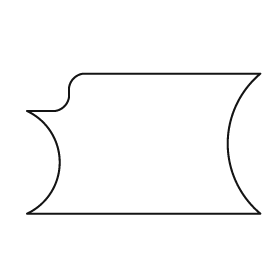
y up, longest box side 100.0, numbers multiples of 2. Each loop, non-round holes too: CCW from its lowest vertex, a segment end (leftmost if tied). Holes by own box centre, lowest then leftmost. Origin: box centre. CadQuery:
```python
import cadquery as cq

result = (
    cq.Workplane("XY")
    .moveTo(-50.0, -30.0)
    .lineTo(50.0, -30.0)
    .threePointArc((36.0, 0.0), (50.0, 30.0))
    .lineTo(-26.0, 30.0)
    .threePointArc((-30.0, 28.0), (-32.0, 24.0))
    .lineTo(-32.0, 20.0)
    .threePointArc((-34.0, 16.0), (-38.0, 14.0))
    .lineTo(-50.0, 14.0)
    .threePointArc((-36.0, -8.0), (-50.0, -30.0))
    .close()
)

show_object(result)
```